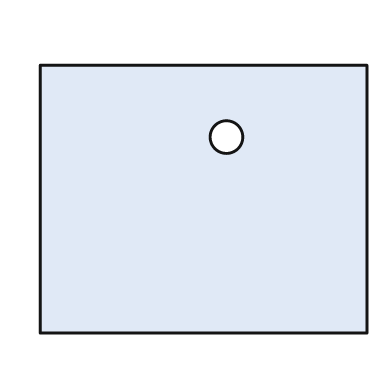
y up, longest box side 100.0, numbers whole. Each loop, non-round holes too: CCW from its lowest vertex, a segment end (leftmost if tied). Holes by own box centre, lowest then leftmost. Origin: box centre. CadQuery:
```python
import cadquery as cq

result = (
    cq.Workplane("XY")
    .moveTo(-50.0, -41.0)
    .lineTo(50.0, -41.0)
    .lineTo(50.0, 41.0)
    .lineTo(-50.0, 41.0)
    .close()
    .moveTo(7.0, 19.0)
    .circle(5.0)
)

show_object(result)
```